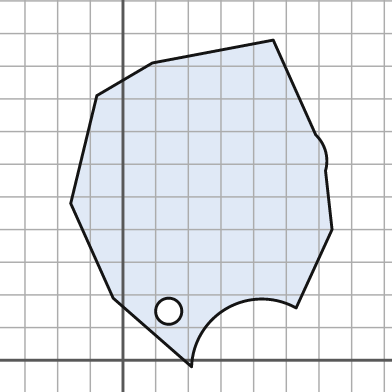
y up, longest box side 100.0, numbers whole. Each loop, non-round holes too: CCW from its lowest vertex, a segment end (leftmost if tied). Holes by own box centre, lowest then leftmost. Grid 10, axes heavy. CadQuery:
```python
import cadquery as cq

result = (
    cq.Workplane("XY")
    .moveTo(21.0, -2.0)
    .threePointArc((32.0, 16.0), (53.0, 16.0))
    .lineTo(64.0, 40.0)
    .lineTo(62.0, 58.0)
    .threePointArc((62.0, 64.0), (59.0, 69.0))
    .lineTo(46.0, 98.0)
    .lineTo(9.0, 91.0)
    .lineTo(-8.0, 81.0)
    .lineTo(-16.0, 48.0)
    .lineTo(-3.0, 19.0)
    .close()
    .moveTo(14.0, 15.0)
    .circle(4.0)
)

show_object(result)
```